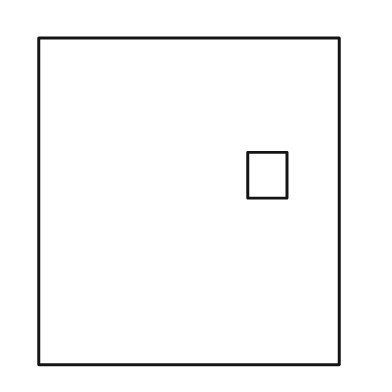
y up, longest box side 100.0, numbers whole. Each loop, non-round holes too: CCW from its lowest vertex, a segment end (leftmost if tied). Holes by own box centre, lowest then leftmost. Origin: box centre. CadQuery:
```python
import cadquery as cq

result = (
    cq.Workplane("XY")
    .moveTo(-46.0, -50.0)
    .lineTo(46.0, -50.0)
    .lineTo(46.0, 50.0)
    .lineTo(-46.0, 50.0)
    .close()
    .moveTo(18.0, 1.0)
    .lineTo(30.0, 1.0)
    .lineTo(30.0, 15.0)
    .lineTo(18.0, 15.0)
    .close()
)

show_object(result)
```